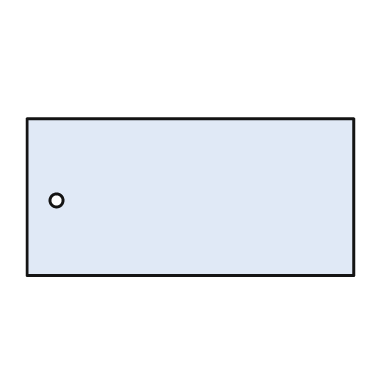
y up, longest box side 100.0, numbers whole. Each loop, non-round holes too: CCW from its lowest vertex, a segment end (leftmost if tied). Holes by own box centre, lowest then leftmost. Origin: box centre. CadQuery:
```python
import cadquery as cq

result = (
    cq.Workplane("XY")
    .moveTo(-50.0, -24.0)
    .lineTo(50.0, -24.0)
    .lineTo(50.0, 24.0)
    .lineTo(-50.0, 24.0)
    .close()
    .moveTo(-41.0, -1.0)
    .circle(2.0)
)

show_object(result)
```